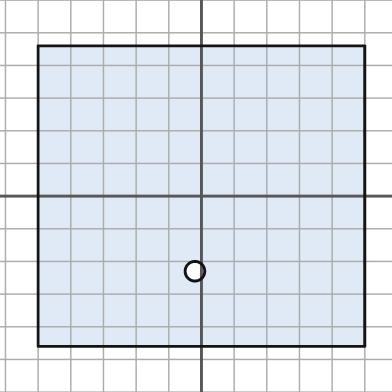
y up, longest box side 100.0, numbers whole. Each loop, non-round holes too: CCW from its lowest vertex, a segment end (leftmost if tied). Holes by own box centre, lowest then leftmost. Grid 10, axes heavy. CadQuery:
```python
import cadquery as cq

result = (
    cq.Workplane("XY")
    .moveTo(-50.0, -46.0)
    .lineTo(50.0, -46.0)
    .lineTo(50.0, 46.0)
    .lineTo(-50.0, 46.0)
    .close()
    .moveTo(-2.0, -23.0)
    .circle(3.0)
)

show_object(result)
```